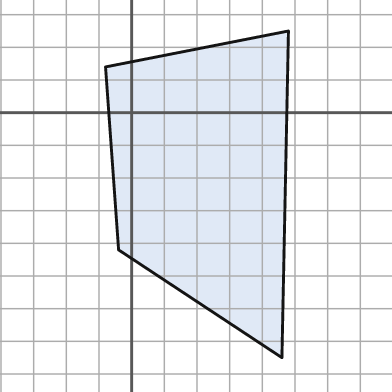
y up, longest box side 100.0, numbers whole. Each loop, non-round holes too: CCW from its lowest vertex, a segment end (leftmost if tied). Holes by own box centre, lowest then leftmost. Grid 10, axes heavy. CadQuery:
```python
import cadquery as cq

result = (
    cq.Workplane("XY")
    .moveTo(46.0, -75.0)
    .lineTo(48.0, 25.0)
    .lineTo(-8.0, 14.0)
    .lineTo(-4.0, -42.0)
    .close()
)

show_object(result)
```